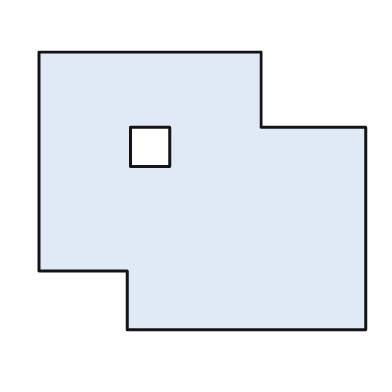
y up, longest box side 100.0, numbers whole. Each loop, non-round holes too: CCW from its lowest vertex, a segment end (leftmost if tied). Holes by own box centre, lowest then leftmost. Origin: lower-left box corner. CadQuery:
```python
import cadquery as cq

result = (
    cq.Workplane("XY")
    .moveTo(27.0, 0.0)
    .lineTo(100.0, 0.0)
    .lineTo(100.0, 62.0)
    .lineTo(68.0, 62.0)
    .lineTo(68.0, 85.0)
    .lineTo(0.0, 85.0)
    .lineTo(0.0, 18.0)
    .lineTo(27.0, 18.0)
    .close()
    .moveTo(28.0, 50.0)
    .lineTo(40.0, 50.0)
    .lineTo(40.0, 62.0)
    .lineTo(28.0, 62.0)
    .close()
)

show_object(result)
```